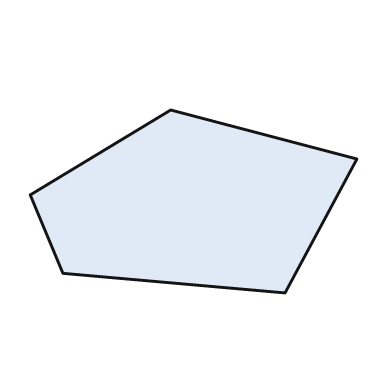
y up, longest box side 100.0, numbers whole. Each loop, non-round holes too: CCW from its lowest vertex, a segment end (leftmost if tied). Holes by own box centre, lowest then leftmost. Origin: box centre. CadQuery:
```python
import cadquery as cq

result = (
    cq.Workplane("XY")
    .moveTo(28.0, -28.0)
    .lineTo(50.0, 13.0)
    .lineTo(-7.0, 28.0)
    .lineTo(-50.0, 2.0)
    .lineTo(-40.0, -22.0)
    .close()
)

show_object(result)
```